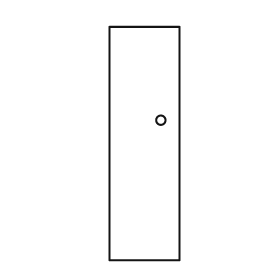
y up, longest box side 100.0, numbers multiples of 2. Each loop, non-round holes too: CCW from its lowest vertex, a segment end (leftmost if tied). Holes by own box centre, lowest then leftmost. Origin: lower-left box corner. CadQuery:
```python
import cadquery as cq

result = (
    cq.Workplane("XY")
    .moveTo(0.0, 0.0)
    .lineTo(30.0, 0.0)
    .lineTo(30.0, 100.0)
    .lineTo(0.0, 100.0)
    .close()
    .moveTo(22.0, 60.0)
    .circle(2.0)
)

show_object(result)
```